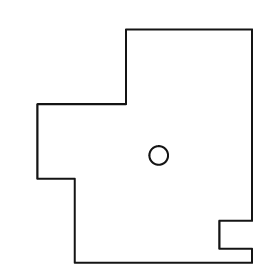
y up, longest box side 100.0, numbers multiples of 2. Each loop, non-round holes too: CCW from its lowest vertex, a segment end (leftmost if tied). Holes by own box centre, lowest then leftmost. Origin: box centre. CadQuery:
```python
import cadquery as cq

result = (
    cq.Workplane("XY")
    .moveTo(-30.0, -50.0)
    .lineTo(46.0, -50.0)
    .lineTo(46.0, -44.0)
    .lineTo(32.0, -44.0)
    .lineTo(32.0, -32.0)
    .lineTo(46.0, -32.0)
    .lineTo(46.0, 50.0)
    .lineTo(-8.0, 50.0)
    .lineTo(-8.0, 18.0)
    .lineTo(-46.0, 18.0)
    .lineTo(-46.0, -14.0)
    .lineTo(-30.0, -14.0)
    .close()
    .moveTo(6.0, -4.0)
    .circle(4.0)
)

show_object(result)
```